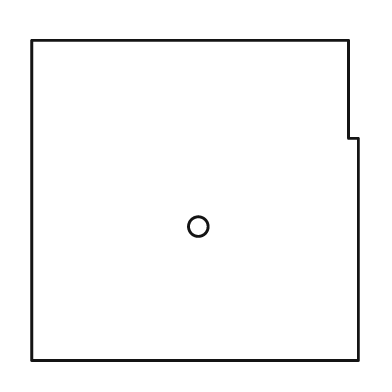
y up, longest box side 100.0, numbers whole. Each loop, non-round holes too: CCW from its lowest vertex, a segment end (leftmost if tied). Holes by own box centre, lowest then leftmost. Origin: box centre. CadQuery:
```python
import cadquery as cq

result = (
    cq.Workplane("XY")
    .moveTo(-50.0, -49.0)
    .lineTo(50.0, -49.0)
    .lineTo(50.0, 19.0)
    .lineTo(47.0, 19.0)
    .lineTo(47.0, 49.0)
    .lineTo(-50.0, 49.0)
    .close()
    .moveTo(1.0, -8.0)
    .circle(3.0)
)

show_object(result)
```